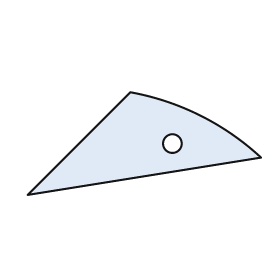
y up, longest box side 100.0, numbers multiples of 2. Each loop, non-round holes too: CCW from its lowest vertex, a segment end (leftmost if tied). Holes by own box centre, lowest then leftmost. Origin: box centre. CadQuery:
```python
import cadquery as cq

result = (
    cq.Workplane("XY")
    .moveTo(-50.0, -22.0)
    .lineTo(50.0, -6.0)
    .threePointArc((24.0, 12.0), (-6.0, 22.0))
    .close()
    .moveTo(12.0, 0.0)
    .circle(4.0)
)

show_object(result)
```